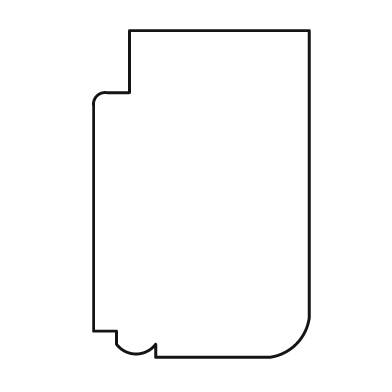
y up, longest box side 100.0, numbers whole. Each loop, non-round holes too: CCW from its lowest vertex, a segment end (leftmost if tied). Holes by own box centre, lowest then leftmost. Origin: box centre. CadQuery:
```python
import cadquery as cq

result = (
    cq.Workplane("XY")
    .moveTo(-14.0, -50.0)
    .lineTo(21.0, -50.0)
    .threePointArc((29.0, -46.0), (33.0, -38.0))
    .lineTo(33.0, 50.0)
    .lineTo(-22.0, 50.0)
    .lineTo(-22.0, 31.0)
    .lineTo(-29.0, 31.0)
    .threePointArc((-32.0, 30.0), (-33.0, 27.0))
    .lineTo(-33.0, -42.0)
    .lineTo(-26.0, -42.0)
    .lineTo(-26.0, -46.0)
    .threePointArc((-20.0, -49.0), (-14.0, -46.0))
    .close()
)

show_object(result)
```